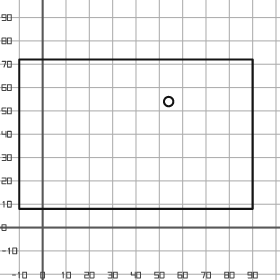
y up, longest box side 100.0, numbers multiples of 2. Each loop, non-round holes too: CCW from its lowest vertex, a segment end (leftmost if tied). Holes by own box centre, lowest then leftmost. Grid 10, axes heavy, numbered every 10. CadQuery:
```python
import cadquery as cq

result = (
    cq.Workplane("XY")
    .moveTo(-10.0, 8.0)
    .lineTo(90.0, 8.0)
    .lineTo(90.0, 72.0)
    .lineTo(-10.0, 72.0)
    .close()
    .moveTo(54.0, 54.0)
    .circle(2.0)
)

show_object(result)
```